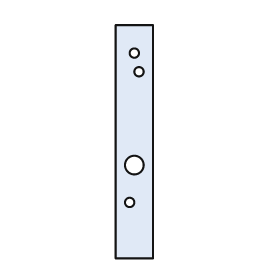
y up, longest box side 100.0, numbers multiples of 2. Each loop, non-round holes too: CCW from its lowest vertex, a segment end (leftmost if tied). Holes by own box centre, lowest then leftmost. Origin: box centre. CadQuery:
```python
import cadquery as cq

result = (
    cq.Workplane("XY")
    .moveTo(-8.0, -50.0)
    .lineTo(8.0, -50.0)
    .lineTo(8.0, 50.0)
    .lineTo(-8.0, 50.0)
    .close()
    .moveTo(-2.0, -26.0)
    .circle(2.0)
    .moveTo(0.0, -10.0)
    .circle(4.0)
    .moveTo(2.0, 30.0)
    .circle(2.0)
    .moveTo(0.0, 38.0)
    .circle(2.0)
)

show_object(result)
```